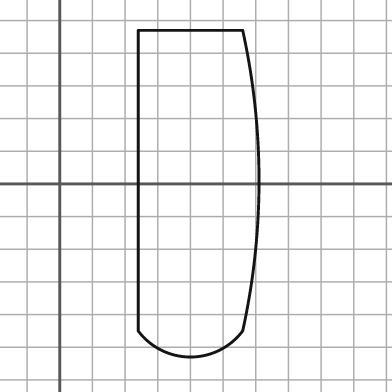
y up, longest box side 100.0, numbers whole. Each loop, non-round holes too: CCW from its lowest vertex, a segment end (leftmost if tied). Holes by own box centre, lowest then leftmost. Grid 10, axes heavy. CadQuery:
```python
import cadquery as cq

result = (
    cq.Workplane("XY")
    .moveTo(24.0, -45.0)
    .threePointArc((40.0, -53.0), (56.0, -45.0))
    .threePointArc((61.0, 1.0), (56.0, 47.0))
    .lineTo(24.0, 47.0)
    .close()
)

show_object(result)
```